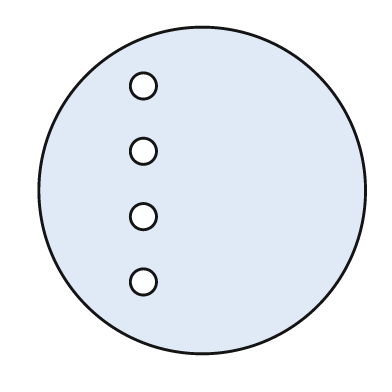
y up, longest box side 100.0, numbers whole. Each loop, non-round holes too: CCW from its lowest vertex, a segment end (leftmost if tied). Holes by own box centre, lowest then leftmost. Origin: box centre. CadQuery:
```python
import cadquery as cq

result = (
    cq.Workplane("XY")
    .moveTo(0.0, 0.0)
    .circle(50.0)
    .moveTo(-18.0, -28.0)
    .circle(4.0)
    .moveTo(-18.0, -8.0)
    .circle(4.0)
    .moveTo(-18.0, 12.0)
    .circle(4.0)
    .moveTo(-18.0, 32.0)
    .circle(4.0)
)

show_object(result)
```